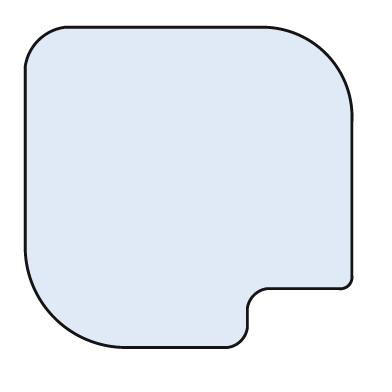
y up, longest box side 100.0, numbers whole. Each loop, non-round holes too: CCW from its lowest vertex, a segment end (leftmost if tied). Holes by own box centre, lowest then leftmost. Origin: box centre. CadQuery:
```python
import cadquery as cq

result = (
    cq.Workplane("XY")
    .moveTo(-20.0, -49.0)
    .lineTo(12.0, -49.0)
    .threePointArc((16.0, -47.0), (18.0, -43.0))
    .lineTo(18.0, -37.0)
    .threePointArc((20.0, -33.0), (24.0, -31.0))
    .lineTo(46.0, -31.0)
    .threePointArc((49.0, -30.0), (50.0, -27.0))
    .lineTo(50.0, 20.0)
    .threePointArc((42.0, 41.0), (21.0, 49.0))
    .lineTo(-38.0, 49.0)
    .threePointArc((-46.0, 45.0), (-50.0, 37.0))
    .lineTo(-50.0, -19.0)
    .threePointArc((-41.0, -40.0), (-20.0, -49.0))
    .close()
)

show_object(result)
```